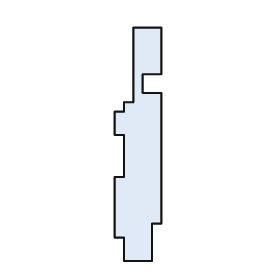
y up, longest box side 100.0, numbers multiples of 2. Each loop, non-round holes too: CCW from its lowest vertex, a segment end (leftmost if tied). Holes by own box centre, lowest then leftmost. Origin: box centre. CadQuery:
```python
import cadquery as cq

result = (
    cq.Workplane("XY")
    .moveTo(-6.0, -50.0)
    .lineTo(6.0, -50.0)
    .lineTo(6.0, -34.0)
    .lineTo(10.0, -34.0)
    .lineTo(10.0, 22.0)
    .lineTo(2.0, 22.0)
    .lineTo(2.0, 30.0)
    .lineTo(10.0, 30.0)
    .lineTo(10.0, 50.0)
    .lineTo(-2.0, 50.0)
    .lineTo(-2.0, 18.0)
    .lineTo(-6.0, 18.0)
    .lineTo(-6.0, 14.0)
    .lineTo(-10.0, 14.0)
    .lineTo(-10.0, 4.0)
    .lineTo(-6.0, 4.0)
    .lineTo(-6.0, -14.0)
    .lineTo(-10.0, -14.0)
    .lineTo(-10.0, -40.0)
    .lineTo(-6.0, -40.0)
    .close()
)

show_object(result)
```